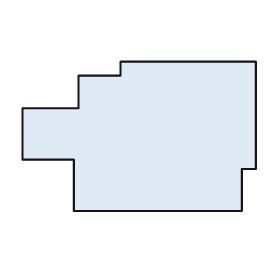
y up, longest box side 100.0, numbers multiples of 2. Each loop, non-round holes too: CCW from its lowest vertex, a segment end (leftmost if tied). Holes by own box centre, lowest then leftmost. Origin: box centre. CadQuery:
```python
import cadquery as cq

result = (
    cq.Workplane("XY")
    .moveTo(-28.0, -32.0)
    .lineTo(44.0, -32.0)
    .lineTo(44.0, -14.0)
    .lineTo(50.0, -14.0)
    .lineTo(50.0, 32.0)
    .lineTo(-8.0, 32.0)
    .lineTo(-8.0, 26.0)
    .lineTo(-26.0, 26.0)
    .lineTo(-26.0, 12.0)
    .lineTo(-50.0, 12.0)
    .lineTo(-50.0, -10.0)
    .lineTo(-28.0, -10.0)
    .close()
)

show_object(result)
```